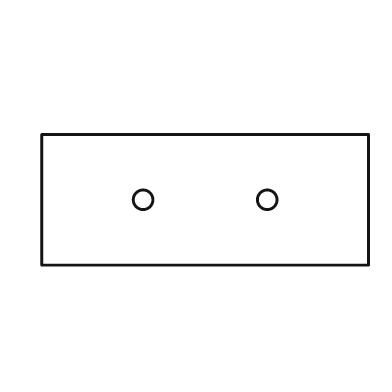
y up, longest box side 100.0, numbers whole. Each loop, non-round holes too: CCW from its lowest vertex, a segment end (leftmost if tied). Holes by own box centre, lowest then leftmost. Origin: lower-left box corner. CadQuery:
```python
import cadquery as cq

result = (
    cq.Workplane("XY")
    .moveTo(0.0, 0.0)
    .lineTo(100.0, 0.0)
    .lineTo(100.0, 40.0)
    .lineTo(0.0, 40.0)
    .close()
    .moveTo(31.0, 20.0)
    .circle(3.0)
    .moveTo(69.0, 20.0)
    .circle(3.0)
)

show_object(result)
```